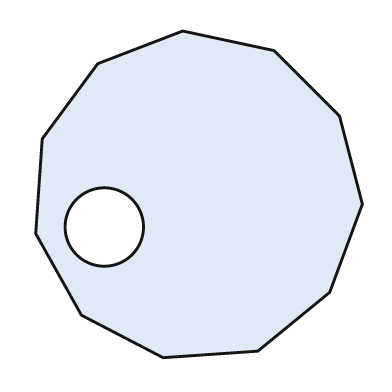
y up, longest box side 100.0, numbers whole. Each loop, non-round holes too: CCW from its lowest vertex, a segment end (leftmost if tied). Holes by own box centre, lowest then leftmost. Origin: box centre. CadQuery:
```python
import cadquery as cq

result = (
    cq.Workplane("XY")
    .moveTo(-11.0, -50.0)
    .lineTo(18.0, -48.0)
    .lineTo(40.0, -30.0)
    .lineTo(50.0, -3.0)
    .lineTo(43.0, 24.0)
    .lineTo(23.0, 44.0)
    .lineTo(-5.0, 50.0)
    .lineTo(-31.0, 40.0)
    .lineTo(-48.0, 17.0)
    .lineTo(-50.0, -12.0)
    .lineTo(-36.0, -37.0)
    .close()
    .moveTo(-29.0, -10.0)
    .circle(12.0)
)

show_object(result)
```